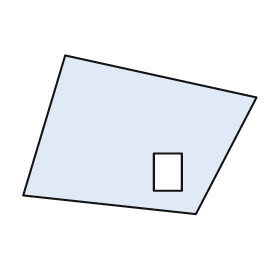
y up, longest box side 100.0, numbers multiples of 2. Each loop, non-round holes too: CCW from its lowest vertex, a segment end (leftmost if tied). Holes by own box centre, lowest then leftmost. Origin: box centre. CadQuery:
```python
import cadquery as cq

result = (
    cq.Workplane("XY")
    .moveTo(24.0, -34.0)
    .lineTo(50.0, 16.0)
    .lineTo(-32.0, 34.0)
    .lineTo(-50.0, -26.0)
    .close()
    .moveTo(6.0, -24.0)
    .lineTo(18.0, -24.0)
    .lineTo(18.0, -8.0)
    .lineTo(6.0, -8.0)
    .close()
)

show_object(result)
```